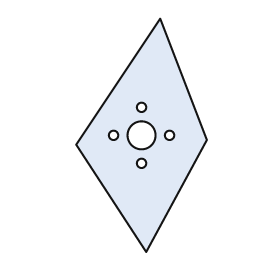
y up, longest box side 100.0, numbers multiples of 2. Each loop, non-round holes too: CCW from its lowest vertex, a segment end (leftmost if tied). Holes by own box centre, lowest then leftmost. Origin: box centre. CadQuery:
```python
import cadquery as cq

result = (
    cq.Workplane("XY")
    .moveTo(2.0, -50.0)
    .lineTo(28.0, -2.0)
    .lineTo(8.0, 50.0)
    .lineTo(-28.0, -4.0)
    .close()
    .moveTo(0.0, -12.0)
    .circle(2.0)
    .moveTo(-12.0, 0.0)
    .circle(2.0)
    .moveTo(0.0, 0.0)
    .circle(6.0)
    .moveTo(12.0, 0.0)
    .circle(2.0)
    .moveTo(0.0, 12.0)
    .circle(2.0)
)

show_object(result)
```